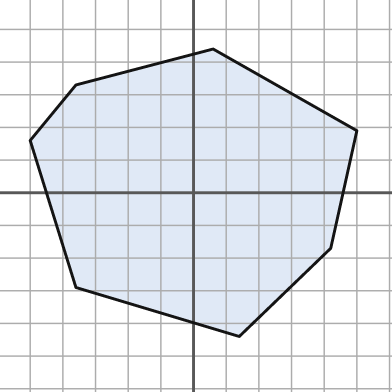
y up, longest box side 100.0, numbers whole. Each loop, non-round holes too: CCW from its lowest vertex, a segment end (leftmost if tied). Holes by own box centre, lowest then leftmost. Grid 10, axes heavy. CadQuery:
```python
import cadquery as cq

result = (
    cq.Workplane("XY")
    .moveTo(14.0, -44.0)
    .lineTo(42.0, -17.0)
    .lineTo(50.0, 19.0)
    .lineTo(6.0, 44.0)
    .lineTo(-36.0, 33.0)
    .lineTo(-50.0, 16.0)
    .lineTo(-36.0, -29.0)
    .close()
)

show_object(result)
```